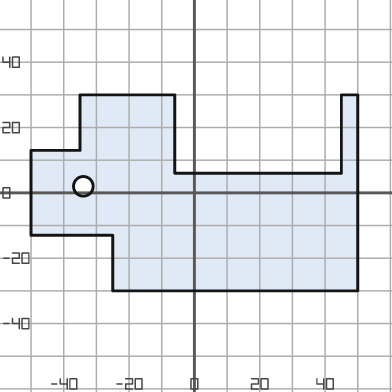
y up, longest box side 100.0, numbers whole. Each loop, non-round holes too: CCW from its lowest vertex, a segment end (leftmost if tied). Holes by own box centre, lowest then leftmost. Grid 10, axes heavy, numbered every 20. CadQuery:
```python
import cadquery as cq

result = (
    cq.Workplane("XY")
    .moveTo(-25.0, -30.0)
    .lineTo(50.0, -30.0)
    .lineTo(50.0, 30.0)
    .lineTo(45.0, 30.0)
    .lineTo(45.0, 6.0)
    .lineTo(-6.0, 6.0)
    .lineTo(-6.0, 30.0)
    .lineTo(-35.0, 30.0)
    .lineTo(-35.0, 13.0)
    .lineTo(-50.0, 13.0)
    .lineTo(-50.0, -13.0)
    .lineTo(-25.0, -13.0)
    .close()
    .moveTo(-34.0, 2.0)
    .circle(3.0)
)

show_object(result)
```